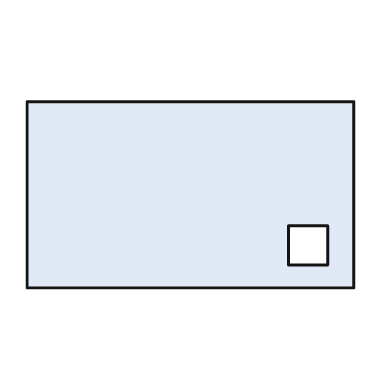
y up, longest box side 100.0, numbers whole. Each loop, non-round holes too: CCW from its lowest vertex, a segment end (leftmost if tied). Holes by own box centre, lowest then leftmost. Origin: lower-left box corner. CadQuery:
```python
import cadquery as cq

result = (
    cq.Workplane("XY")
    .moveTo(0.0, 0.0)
    .lineTo(100.0, 0.0)
    .lineTo(100.0, 57.0)
    .lineTo(0.0, 57.0)
    .close()
    .moveTo(80.0, 7.0)
    .lineTo(92.0, 7.0)
    .lineTo(92.0, 19.0)
    .lineTo(80.0, 19.0)
    .close()
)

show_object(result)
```